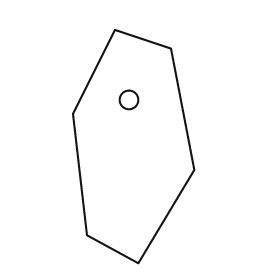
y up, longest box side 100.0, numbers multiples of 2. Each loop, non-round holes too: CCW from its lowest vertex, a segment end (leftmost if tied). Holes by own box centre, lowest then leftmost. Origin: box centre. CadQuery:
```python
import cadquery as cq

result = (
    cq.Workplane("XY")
    .moveTo(2.0, -50.0)
    .lineTo(26.0, -10.0)
    .lineTo(16.0, 42.0)
    .lineTo(-8.0, 50.0)
    .lineTo(-26.0, 14.0)
    .lineTo(-20.0, -38.0)
    .close()
    .moveTo(-2.0, 20.0)
    .circle(4.0)
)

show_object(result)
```